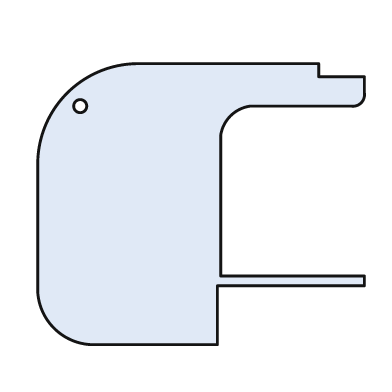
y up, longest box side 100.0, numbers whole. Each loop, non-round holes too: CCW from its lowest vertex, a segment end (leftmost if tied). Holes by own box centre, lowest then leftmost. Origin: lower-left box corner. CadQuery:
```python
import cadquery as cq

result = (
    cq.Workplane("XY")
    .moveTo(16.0, 0.0)
    .lineTo(55.0, 0.0)
    .lineTo(55.0, 18.0)
    .lineTo(100.0, 18.0)
    .lineTo(100.0, 21.0)
    .lineTo(56.0, 21.0)
    .lineTo(56.0, 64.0)
    .threePointArc((59.0, 70.0), (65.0, 73.0))
    .lineTo(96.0, 73.0)
    .threePointArc((99.0, 74.0), (100.0, 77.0))
    .lineTo(100.0, 82.0)
    .lineTo(86.0, 82.0)
    .lineTo(86.0, 86.0)
    .lineTo(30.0, 86.0)
    .threePointArc((9.0, 77.0), (0.0, 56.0))
    .lineTo(0.0, 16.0)
    .threePointArc((5.0, 5.0), (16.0, 0.0))
    .close()
    .moveTo(13.0, 73.0)
    .circle(2.0)
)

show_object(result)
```